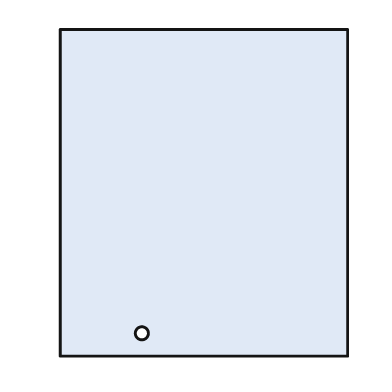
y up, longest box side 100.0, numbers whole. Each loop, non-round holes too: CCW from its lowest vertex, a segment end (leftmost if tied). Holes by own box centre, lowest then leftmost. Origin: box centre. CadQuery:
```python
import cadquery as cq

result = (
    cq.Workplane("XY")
    .moveTo(-44.0, -50.0)
    .lineTo(44.0, -50.0)
    .lineTo(44.0, 50.0)
    .lineTo(-44.0, 50.0)
    .close()
    .moveTo(-19.0, -43.0)
    .circle(2.0)
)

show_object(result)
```